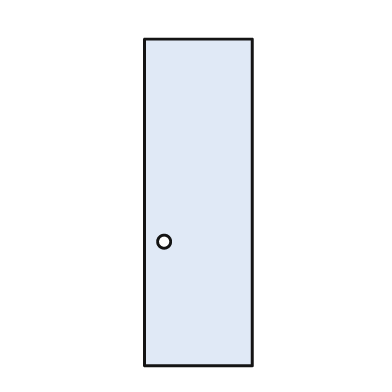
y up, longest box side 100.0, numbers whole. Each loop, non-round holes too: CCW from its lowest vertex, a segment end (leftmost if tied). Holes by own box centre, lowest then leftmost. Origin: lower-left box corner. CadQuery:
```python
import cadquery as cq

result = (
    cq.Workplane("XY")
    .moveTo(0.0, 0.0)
    .lineTo(33.0, 0.0)
    .lineTo(33.0, 100.0)
    .lineTo(0.0, 100.0)
    .close()
    .moveTo(6.0, 38.0)
    .circle(2.0)
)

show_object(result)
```